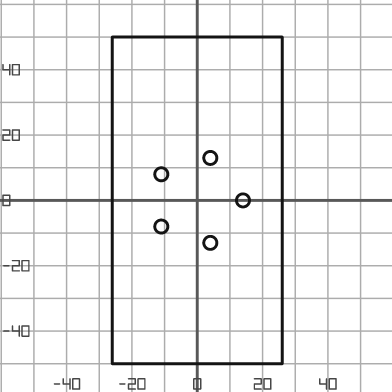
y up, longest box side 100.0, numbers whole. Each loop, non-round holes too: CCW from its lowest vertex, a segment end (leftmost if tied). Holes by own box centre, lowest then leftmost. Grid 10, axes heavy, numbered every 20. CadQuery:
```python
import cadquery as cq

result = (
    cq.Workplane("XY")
    .moveTo(-26.0, -50.0)
    .lineTo(26.0, -50.0)
    .lineTo(26.0, 50.0)
    .lineTo(-26.0, 50.0)
    .close()
    .moveTo(4.0, -13.0)
    .circle(2.0)
    .moveTo(-11.0, -8.0)
    .circle(2.0)
    .moveTo(14.0, 0.0)
    .circle(2.0)
    .moveTo(-11.0, 8.0)
    .circle(2.0)
    .moveTo(4.0, 13.0)
    .circle(2.0)
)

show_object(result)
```